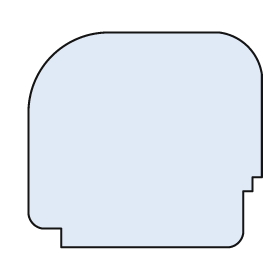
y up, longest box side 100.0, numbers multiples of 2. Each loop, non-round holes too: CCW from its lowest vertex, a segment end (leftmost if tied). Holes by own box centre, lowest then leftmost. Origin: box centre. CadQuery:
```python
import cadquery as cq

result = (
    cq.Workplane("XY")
    .moveTo(-36.0, -46.0)
    .lineTo(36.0, -46.0)
    .threePointArc((40.0, -44.0), (42.0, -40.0))
    .lineTo(42.0, -22.0)
    .lineTo(46.0, -22.0)
    .lineTo(46.0, -16.0)
    .lineTo(50.0, -16.0)
    .lineTo(50.0, 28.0)
    .threePointArc((44.0, 40.0), (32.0, 46.0))
    .lineTo(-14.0, 46.0)
    .threePointArc((-40.0, 36.0), (-50.0, 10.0))
    .lineTo(-50.0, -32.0)
    .threePointArc((-48.0, -36.0), (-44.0, -38.0))
    .lineTo(-36.0, -38.0)
    .close()
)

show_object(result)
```